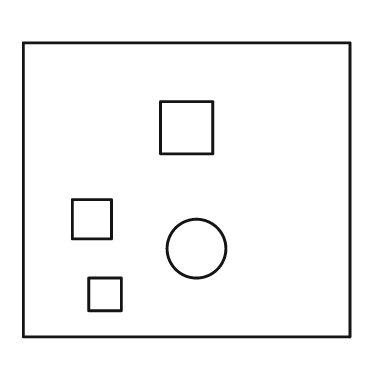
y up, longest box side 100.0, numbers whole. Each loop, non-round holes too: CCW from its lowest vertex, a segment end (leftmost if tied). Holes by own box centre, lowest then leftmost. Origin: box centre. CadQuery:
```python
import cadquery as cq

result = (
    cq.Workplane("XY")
    .moveTo(-50.0, -45.0)
    .lineTo(50.0, -45.0)
    .lineTo(50.0, 45.0)
    .lineTo(-50.0, 45.0)
    .close()
    .moveTo(-30.0, -37.0)
    .lineTo(-20.0, -37.0)
    .lineTo(-20.0, -27.0)
    .lineTo(-30.0, -27.0)
    .close()
    .moveTo(3.0, -18.0)
    .circle(9.0)
    .moveTo(-35.0, -15.0)
    .lineTo(-23.0, -15.0)
    .lineTo(-23.0, -3.0)
    .lineTo(-35.0, -3.0)
    .close()
    .moveTo(-8.0, 11.0)
    .lineTo(8.0, 11.0)
    .lineTo(8.0, 27.0)
    .lineTo(-8.0, 27.0)
    .close()
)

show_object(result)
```